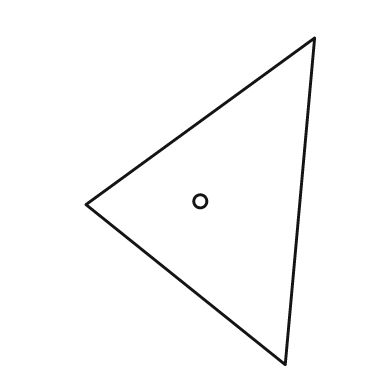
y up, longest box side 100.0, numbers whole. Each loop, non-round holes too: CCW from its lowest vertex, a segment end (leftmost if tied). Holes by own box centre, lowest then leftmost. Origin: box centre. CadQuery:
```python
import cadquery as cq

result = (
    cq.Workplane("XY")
    .moveTo(26.0, -50.0)
    .lineTo(35.0, 50.0)
    .lineTo(-35.0, -1.0)
    .close()
    .moveTo(0.0, 0.0)
    .circle(2.0)
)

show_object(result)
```